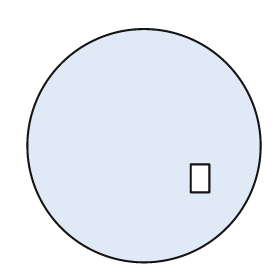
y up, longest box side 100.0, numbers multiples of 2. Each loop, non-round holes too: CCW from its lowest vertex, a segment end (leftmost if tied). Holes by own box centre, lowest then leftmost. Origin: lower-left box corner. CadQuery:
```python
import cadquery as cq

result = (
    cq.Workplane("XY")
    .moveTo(50.0, 50.0)
    .circle(50.0)
    .moveTo(70.0, 30.0)
    .lineTo(78.0, 30.0)
    .lineTo(78.0, 42.0)
    .lineTo(70.0, 42.0)
    .close()
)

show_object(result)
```